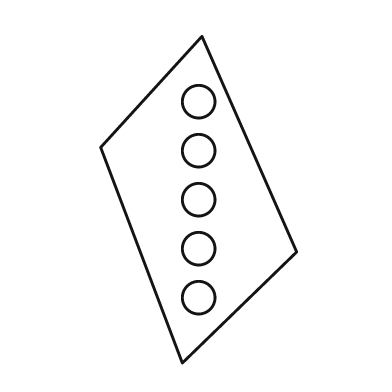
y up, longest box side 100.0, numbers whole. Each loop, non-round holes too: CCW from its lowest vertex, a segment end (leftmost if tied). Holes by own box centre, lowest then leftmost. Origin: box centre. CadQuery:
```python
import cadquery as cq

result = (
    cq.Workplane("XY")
    .moveTo(-5.0, -50.0)
    .lineTo(30.0, -16.0)
    .lineTo(1.0, 50.0)
    .lineTo(-30.0, 16.0)
    .close()
    .moveTo(0.0, -30.0)
    .circle(5.0)
    .moveTo(0.0, -15.0)
    .circle(5.0)
    .moveTo(0.0, 0.0)
    .circle(5.0)
    .moveTo(0.0, 15.0)
    .circle(5.0)
    .moveTo(0.0, 30.0)
    .circle(5.0)
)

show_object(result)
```